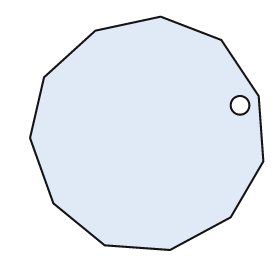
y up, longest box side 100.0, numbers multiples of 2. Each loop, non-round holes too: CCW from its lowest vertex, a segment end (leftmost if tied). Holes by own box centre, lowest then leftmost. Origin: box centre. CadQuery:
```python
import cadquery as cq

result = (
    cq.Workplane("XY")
    .moveTo(10.0, -50.0)
    .lineTo(36.0, -36.0)
    .lineTo(50.0, -12.0)
    .lineTo(48.0, 16.0)
    .lineTo(32.0, 40.0)
    .lineTo(6.0, 50.0)
    .lineTo(-22.0, 44.0)
    .lineTo(-44.0, 24.0)
    .lineTo(-50.0, -2.0)
    .lineTo(-40.0, -30.0)
    .lineTo(-18.0, -48.0)
    .close()
    .moveTo(40.0, 12.0)
    .circle(4.0)
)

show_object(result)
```